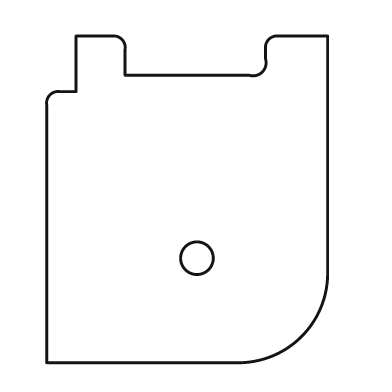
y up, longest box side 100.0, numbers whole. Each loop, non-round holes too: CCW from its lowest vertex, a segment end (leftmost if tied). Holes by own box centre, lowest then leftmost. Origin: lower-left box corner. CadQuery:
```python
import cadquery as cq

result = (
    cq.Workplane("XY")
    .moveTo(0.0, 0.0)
    .lineTo(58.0, 0.0)
    .threePointArc((78.0, 8.0), (86.0, 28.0))
    .lineTo(86.0, 100.0)
    .lineTo(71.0, 100.0)
    .threePointArc((68.0, 99.0), (67.0, 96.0))
    .lineTo(67.0, 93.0)
    .threePointArc((66.0, 89.0), (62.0, 88.0))
    .lineTo(24.0, 88.0)
    .lineTo(24.0, 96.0)
    .threePointArc((23.0, 99.0), (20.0, 100.0))
    .lineTo(9.0, 100.0)
    .lineTo(9.0, 83.0)
    .lineTo(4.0, 83.0)
    .threePointArc((1.0, 82.0), (0.0, 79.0))
    .close()
    .moveTo(46.0, 32.0)
    .circle(5.0)
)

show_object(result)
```